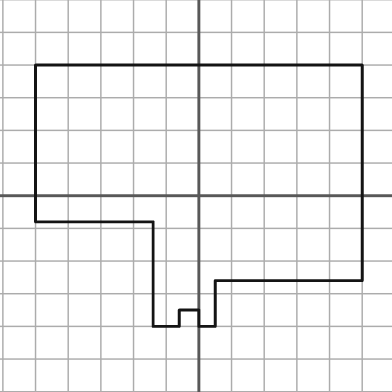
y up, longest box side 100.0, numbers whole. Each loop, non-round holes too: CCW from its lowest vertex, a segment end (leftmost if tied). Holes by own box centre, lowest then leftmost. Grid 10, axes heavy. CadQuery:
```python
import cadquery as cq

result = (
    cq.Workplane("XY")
    .moveTo(-14.0, -40.0)
    .lineTo(-6.0, -40.0)
    .lineTo(-6.0, -35.0)
    .lineTo(0.0, -35.0)
    .lineTo(0.0, -40.0)
    .lineTo(5.0, -40.0)
    .lineTo(5.0, -26.0)
    .lineTo(50.0, -26.0)
    .lineTo(50.0, 40.0)
    .lineTo(-50.0, 40.0)
    .lineTo(-50.0, -8.0)
    .lineTo(-14.0, -8.0)
    .close()
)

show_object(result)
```